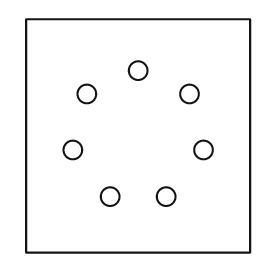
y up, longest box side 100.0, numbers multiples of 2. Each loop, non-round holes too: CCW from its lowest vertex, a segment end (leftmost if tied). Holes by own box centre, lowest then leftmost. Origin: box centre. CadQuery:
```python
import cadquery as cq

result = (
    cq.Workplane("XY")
    .moveTo(-48.0, -50.0)
    .lineTo(48.0, -50.0)
    .lineTo(48.0, 50.0)
    .lineTo(-48.0, 50.0)
    .close()
    .moveTo(-12.0, -26.0)
    .circle(4.0)
    .moveTo(12.0, -26.0)
    .circle(4.0)
    .moveTo(-28.0, -6.0)
    .circle(4.0)
    .moveTo(28.0, -6.0)
    .circle(4.0)
    .moveTo(-22.0, 18.0)
    .circle(4.0)
    .moveTo(22.0, 18.0)
    .circle(4.0)
    .moveTo(0.0, 28.0)
    .circle(4.0)
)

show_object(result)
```